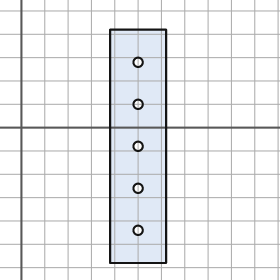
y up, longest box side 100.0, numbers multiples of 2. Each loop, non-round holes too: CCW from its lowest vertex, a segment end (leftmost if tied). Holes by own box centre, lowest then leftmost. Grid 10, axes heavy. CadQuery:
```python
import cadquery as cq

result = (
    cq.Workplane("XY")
    .moveTo(38.0, -58.0)
    .lineTo(62.0, -58.0)
    .lineTo(62.0, 42.0)
    .lineTo(38.0, 42.0)
    .close()
    .moveTo(50.0, -44.0)
    .circle(2.0)
    .moveTo(50.0, -26.0)
    .circle(2.0)
    .moveTo(50.0, -8.0)
    .circle(2.0)
    .moveTo(50.0, 10.0)
    .circle(2.0)
    .moveTo(50.0, 28.0)
    .circle(2.0)
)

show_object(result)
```